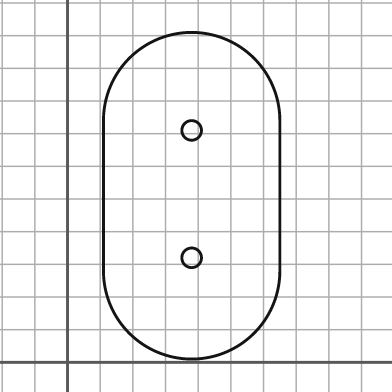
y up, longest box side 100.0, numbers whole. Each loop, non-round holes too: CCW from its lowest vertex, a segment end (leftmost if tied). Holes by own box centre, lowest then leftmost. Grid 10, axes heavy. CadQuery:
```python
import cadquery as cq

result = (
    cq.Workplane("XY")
    .moveTo(11.0, 28.0)
    .threePointArc((38.0, 1.0), (65.0, 28.0))
    .lineTo(65.0, 74.0)
    .threePointArc((38.0, 101.0), (11.0, 74.0))
    .close()
    .moveTo(38.0, 32.0)
    .circle(3.0)
    .moveTo(38.0, 71.0)
    .circle(3.0)
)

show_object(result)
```